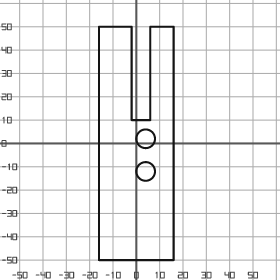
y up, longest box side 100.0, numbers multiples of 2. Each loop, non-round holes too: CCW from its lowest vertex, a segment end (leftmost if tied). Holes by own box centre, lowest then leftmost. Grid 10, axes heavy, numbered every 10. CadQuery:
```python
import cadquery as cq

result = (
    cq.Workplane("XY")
    .moveTo(-16.0, -50.0)
    .lineTo(16.0, -50.0)
    .lineTo(16.0, 50.0)
    .lineTo(6.0, 50.0)
    .lineTo(6.0, 10.0)
    .lineTo(-2.0, 10.0)
    .lineTo(-2.0, 50.0)
    .lineTo(-16.0, 50.0)
    .close()
    .moveTo(4.0, -12.0)
    .circle(4.0)
    .moveTo(4.0, 2.0)
    .circle(4.0)
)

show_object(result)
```